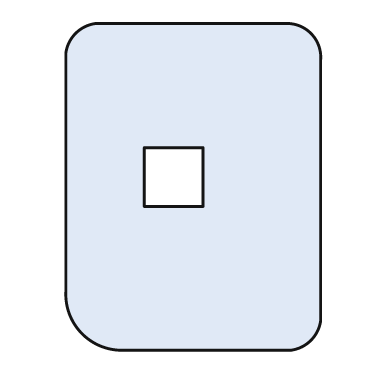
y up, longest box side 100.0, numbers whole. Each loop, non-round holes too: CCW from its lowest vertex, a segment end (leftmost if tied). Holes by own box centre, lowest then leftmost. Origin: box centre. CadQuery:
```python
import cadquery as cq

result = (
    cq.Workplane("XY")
    .moveTo(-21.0, -50.0)
    .lineTo(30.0, -50.0)
    .threePointArc((36.0, -47.0), (39.0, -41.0))
    .lineTo(39.0, 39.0)
    .threePointArc((36.0, 47.0), (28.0, 50.0))
    .lineTo(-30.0, 50.0)
    .threePointArc((-36.0, 47.0), (-39.0, 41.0))
    .lineTo(-39.0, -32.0)
    .threePointArc((-34.0, -45.0), (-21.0, -50.0))
    .close()
    .moveTo(-15.0, -6.0)
    .lineTo(3.0, -6.0)
    .lineTo(3.0, 12.0)
    .lineTo(-15.0, 12.0)
    .close()
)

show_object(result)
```